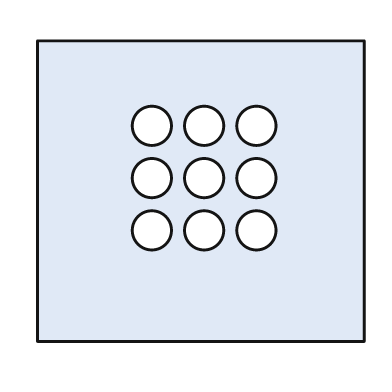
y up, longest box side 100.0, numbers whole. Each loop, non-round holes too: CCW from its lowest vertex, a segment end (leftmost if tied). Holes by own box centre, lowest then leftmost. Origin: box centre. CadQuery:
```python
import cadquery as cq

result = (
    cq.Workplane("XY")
    .moveTo(-50.0, -46.0)
    .lineTo(50.0, -46.0)
    .lineTo(50.0, 46.0)
    .lineTo(-50.0, 46.0)
    .close()
    .moveTo(-15.0, -12.0)
    .circle(6.0)
    .moveTo(1.0, -12.0)
    .circle(6.0)
    .moveTo(17.0, -12.0)
    .circle(6.0)
    .moveTo(-15.0, 4.0)
    .circle(6.0)
    .moveTo(1.0, 4.0)
    .circle(6.0)
    .moveTo(17.0, 4.0)
    .circle(6.0)
    .moveTo(-15.0, 20.0)
    .circle(6.0)
    .moveTo(1.0, 20.0)
    .circle(6.0)
    .moveTo(17.0, 20.0)
    .circle(6.0)
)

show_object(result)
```